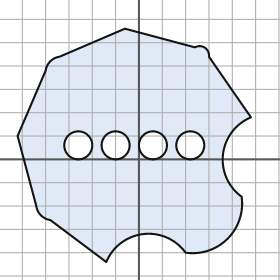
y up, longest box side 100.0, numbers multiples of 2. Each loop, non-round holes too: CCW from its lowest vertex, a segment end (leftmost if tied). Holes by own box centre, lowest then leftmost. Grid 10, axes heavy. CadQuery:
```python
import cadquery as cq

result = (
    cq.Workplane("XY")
    .moveTo(-14.0, -44.0)
    .threePointArc((2.0, -32.0), (20.0, -40.0))
    .threePointArc((38.0, -34.0), (44.0, -16.0))
    .threePointArc((36.0, 2.0), (48.0, 18.0))
    .lineTo(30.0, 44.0)
    .threePointArc((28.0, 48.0), (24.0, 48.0))
    .lineTo(-6.0, 56.0)
    .lineTo(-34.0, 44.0)
    .threePointArc((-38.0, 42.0), (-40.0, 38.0))
    .lineTo(-52.0, 10.0)
    .lineTo(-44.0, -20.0)
    .threePointArc((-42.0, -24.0), (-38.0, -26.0))
    .close()
    .moveTo(-26.0, 6.0)
    .circle(6.0)
    .moveTo(-10.0, 6.0)
    .circle(6.0)
    .moveTo(6.0, 6.0)
    .circle(6.0)
    .moveTo(22.0, 6.0)
    .circle(6.0)
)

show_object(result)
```